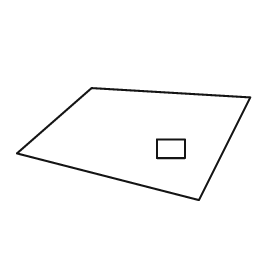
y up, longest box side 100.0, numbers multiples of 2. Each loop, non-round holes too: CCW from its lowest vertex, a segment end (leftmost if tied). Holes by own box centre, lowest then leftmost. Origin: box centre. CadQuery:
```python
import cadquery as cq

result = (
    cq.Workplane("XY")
    .moveTo(28.0, -24.0)
    .lineTo(50.0, 20.0)
    .lineTo(-18.0, 24.0)
    .lineTo(-50.0, -4.0)
    .close()
    .moveTo(10.0, -6.0)
    .lineTo(22.0, -6.0)
    .lineTo(22.0, 2.0)
    .lineTo(10.0, 2.0)
    .close()
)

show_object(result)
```